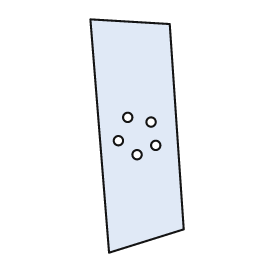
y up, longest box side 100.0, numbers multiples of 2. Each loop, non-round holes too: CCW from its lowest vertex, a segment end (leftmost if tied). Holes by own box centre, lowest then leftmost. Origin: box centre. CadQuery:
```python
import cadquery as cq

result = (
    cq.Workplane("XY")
    .moveTo(-12.0, -50.0)
    .lineTo(20.0, -40.0)
    .lineTo(14.0, 48.0)
    .lineTo(-20.0, 50.0)
    .close()
    .moveTo(0.0, -8.0)
    .circle(2.0)
    .moveTo(8.0, -4.0)
    .circle(2.0)
    .moveTo(-8.0, -2.0)
    .circle(2.0)
    .moveTo(6.0, 6.0)
    .circle(2.0)
    .moveTo(-4.0, 8.0)
    .circle(2.0)
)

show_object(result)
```